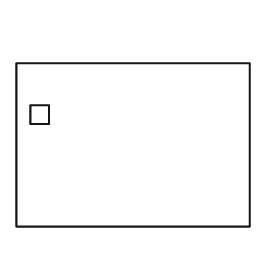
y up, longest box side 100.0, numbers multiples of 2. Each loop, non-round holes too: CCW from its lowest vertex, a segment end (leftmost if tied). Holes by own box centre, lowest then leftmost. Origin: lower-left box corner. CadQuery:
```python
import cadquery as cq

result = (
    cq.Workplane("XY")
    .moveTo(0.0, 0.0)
    .lineTo(100.0, 0.0)
    .lineTo(100.0, 70.0)
    .lineTo(0.0, 70.0)
    .close()
    .moveTo(6.0, 44.0)
    .lineTo(14.0, 44.0)
    .lineTo(14.0, 52.0)
    .lineTo(6.0, 52.0)
    .close()
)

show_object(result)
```